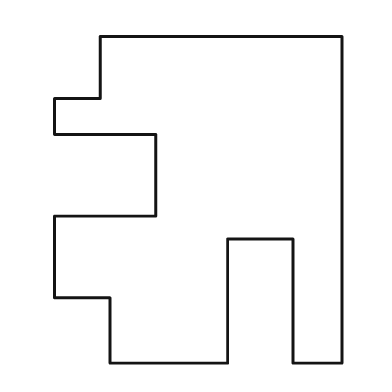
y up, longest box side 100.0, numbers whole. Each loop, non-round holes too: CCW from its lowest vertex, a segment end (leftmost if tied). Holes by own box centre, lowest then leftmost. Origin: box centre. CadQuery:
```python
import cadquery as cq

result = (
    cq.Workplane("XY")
    .moveTo(-27.0, -50.0)
    .lineTo(9.0, -50.0)
    .lineTo(9.0, -12.0)
    .lineTo(29.0, -12.0)
    .lineTo(29.0, -50.0)
    .lineTo(44.0, -50.0)
    .lineTo(44.0, 50.0)
    .lineTo(-30.0, 50.0)
    .lineTo(-30.0, 31.0)
    .lineTo(-44.0, 31.0)
    .lineTo(-44.0, 20.0)
    .lineTo(-13.0, 20.0)
    .lineTo(-13.0, -5.0)
    .lineTo(-44.0, -5.0)
    .lineTo(-44.0, -30.0)
    .lineTo(-27.0, -30.0)
    .close()
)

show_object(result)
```